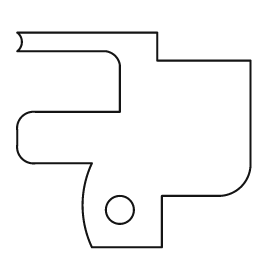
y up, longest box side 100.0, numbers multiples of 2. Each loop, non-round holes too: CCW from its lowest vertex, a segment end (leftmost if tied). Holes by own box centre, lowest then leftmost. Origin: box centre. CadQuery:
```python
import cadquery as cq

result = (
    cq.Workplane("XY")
    .moveTo(-18.0, -46.0)
    .lineTo(12.0, -46.0)
    .lineTo(12.0, -24.0)
    .lineTo(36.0, -24.0)
    .threePointArc((46.0, -20.0), (50.0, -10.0))
    .lineTo(50.0, 34.0)
    .lineTo(10.0, 34.0)
    .lineTo(10.0, 46.0)
    .lineTo(-50.0, 46.0)
    .threePointArc((-48.0, 42.0), (-50.0, 38.0))
    .lineTo(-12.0, 38.0)
    .threePointArc((-8.0, 36.0), (-6.0, 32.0))
    .lineTo(-6.0, 12.0)
    .lineTo(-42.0, 12.0)
    .threePointArc((-48.0, 10.0), (-50.0, 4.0))
    .lineTo(-50.0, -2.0)
    .threePointArc((-48.0, -8.0), (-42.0, -10.0))
    .lineTo(-18.0, -10.0)
    .threePointArc((-22.0, -28.0), (-18.0, -46.0))
    .close()
    .moveTo(-6.0, -30.0)
    .circle(6.0)
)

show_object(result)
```